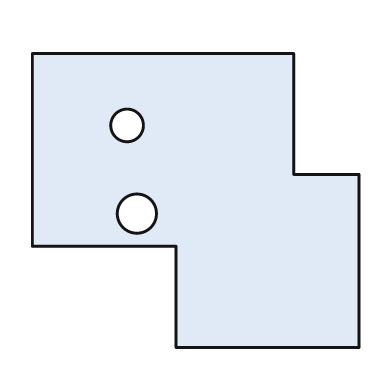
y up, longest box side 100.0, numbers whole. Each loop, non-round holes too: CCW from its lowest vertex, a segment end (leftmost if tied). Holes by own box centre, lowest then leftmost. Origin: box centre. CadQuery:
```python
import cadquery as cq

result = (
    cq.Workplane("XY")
    .moveTo(-6.0, -45.0)
    .lineTo(50.0, -45.0)
    .lineTo(50.0, 8.0)
    .lineTo(30.0, 8.0)
    .lineTo(30.0, 45.0)
    .lineTo(-50.0, 45.0)
    .lineTo(-50.0, -14.0)
    .lineTo(-6.0, -14.0)
    .close()
    .moveTo(-18.0, -4.0)
    .circle(6.0)
    .moveTo(-21.0, 23.0)
    .circle(5.0)
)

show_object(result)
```